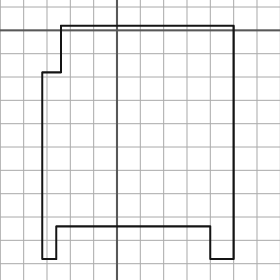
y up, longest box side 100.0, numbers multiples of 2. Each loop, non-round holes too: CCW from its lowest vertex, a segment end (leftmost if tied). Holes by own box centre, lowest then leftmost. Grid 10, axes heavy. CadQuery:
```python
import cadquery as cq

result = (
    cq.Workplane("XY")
    .moveTo(-32.0, -98.0)
    .lineTo(-26.0, -98.0)
    .lineTo(-26.0, -84.0)
    .lineTo(40.0, -84.0)
    .lineTo(40.0, -98.0)
    .lineTo(50.0, -98.0)
    .lineTo(50.0, 2.0)
    .lineTo(-24.0, 2.0)
    .lineTo(-24.0, -18.0)
    .lineTo(-32.0, -18.0)
    .close()
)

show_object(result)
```